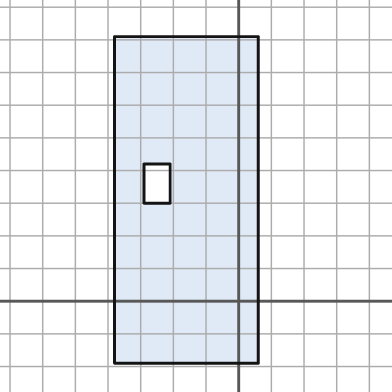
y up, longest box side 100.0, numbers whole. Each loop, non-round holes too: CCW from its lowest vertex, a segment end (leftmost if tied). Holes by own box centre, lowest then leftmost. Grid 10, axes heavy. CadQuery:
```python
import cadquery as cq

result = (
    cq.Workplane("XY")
    .moveTo(-38.0, -19.0)
    .lineTo(6.0, -19.0)
    .lineTo(6.0, 81.0)
    .lineTo(-38.0, 81.0)
    .close()
    .moveTo(-29.0, 30.0)
    .lineTo(-21.0, 30.0)
    .lineTo(-21.0, 42.0)
    .lineTo(-29.0, 42.0)
    .close()
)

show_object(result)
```